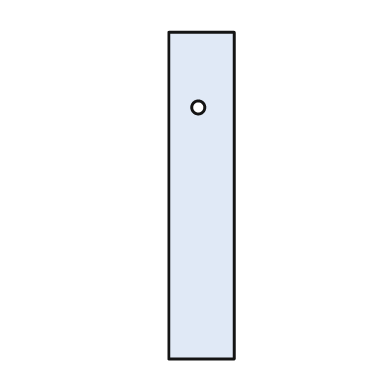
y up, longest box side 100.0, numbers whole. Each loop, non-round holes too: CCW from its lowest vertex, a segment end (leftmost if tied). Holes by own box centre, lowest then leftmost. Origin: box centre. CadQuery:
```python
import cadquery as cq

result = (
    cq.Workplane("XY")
    .moveTo(-10.0, -50.0)
    .lineTo(10.0, -50.0)
    .lineTo(10.0, 50.0)
    .lineTo(-10.0, 50.0)
    .close()
    .moveTo(-1.0, 27.0)
    .circle(2.0)
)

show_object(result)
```